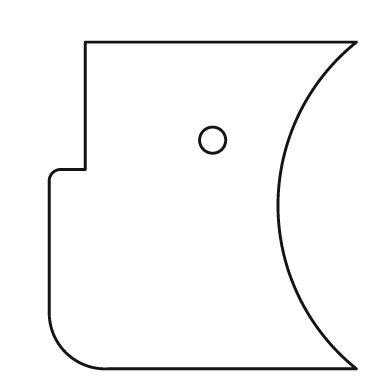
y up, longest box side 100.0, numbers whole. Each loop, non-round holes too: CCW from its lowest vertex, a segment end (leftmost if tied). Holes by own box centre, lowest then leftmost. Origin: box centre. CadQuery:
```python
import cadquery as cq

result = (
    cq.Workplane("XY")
    .moveTo(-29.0, -50.0)
    .lineTo(47.0, -50.0)
    .threePointArc((23.0, 0.0), (47.0, 50.0))
    .lineTo(-36.0, 50.0)
    .lineTo(-36.0, 11.0)
    .lineTo(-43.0, 11.0)
    .threePointArc((-46.0, 10.0), (-47.0, 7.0))
    .lineTo(-47.0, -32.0)
    .threePointArc((-42.0, -45.0), (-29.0, -50.0))
    .close()
    .moveTo(3.0, 20.0)
    .circle(4.0)
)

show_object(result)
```